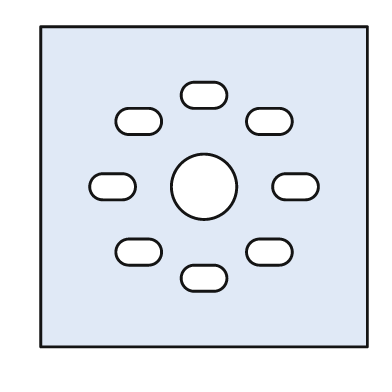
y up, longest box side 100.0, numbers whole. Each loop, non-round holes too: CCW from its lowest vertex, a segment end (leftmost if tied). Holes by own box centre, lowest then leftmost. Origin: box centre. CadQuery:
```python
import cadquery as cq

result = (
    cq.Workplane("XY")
    .moveTo(-50.0, -49.0)
    .lineTo(50.0, -49.0)
    .lineTo(50.0, 49.0)
    .lineTo(-50.0, 49.0)
    .close()
    .moveTo(-3.0, -32.0)
    .lineTo(3.0, -32.0)
    .threePointArc((7.0, -28.0), (3.0, -24.0))
    .lineTo(-3.0, -24.0)
    .threePointArc((-7.0, -28.0), (-3.0, -32.0))
    .close()
    .moveTo(-23.0, -24.0)
    .lineTo(-17.0, -24.0)
    .threePointArc((-13.0, -20.0), (-17.0, -16.0))
    .lineTo(-23.0, -16.0)
    .threePointArc((-27.0, -20.0), (-23.0, -24.0))
    .close()
    .moveTo(17.0, -24.0)
    .lineTo(23.0, -24.0)
    .threePointArc((27.0, -20.0), (23.0, -16.0))
    .lineTo(17.0, -16.0)
    .threePointArc((13.0, -20.0), (17.0, -24.0))
    .close()
    .moveTo(-31.0, -4.0)
    .lineTo(-25.0, -4.0)
    .threePointArc((-21.0, 0.0), (-25.0, 4.0))
    .lineTo(-31.0, 4.0)
    .threePointArc((-35.0, 0.0), (-31.0, -4.0))
    .close()
    .moveTo(0.0, 0.0)
    .circle(10.0)
    .moveTo(25.0, -4.0)
    .lineTo(31.0, -4.0)
    .threePointArc((35.0, 0.0), (31.0, 4.0))
    .lineTo(25.0, 4.0)
    .threePointArc((21.0, 0.0), (25.0, -4.0))
    .close()
    .moveTo(-23.0, 16.0)
    .lineTo(-17.0, 16.0)
    .threePointArc((-13.0, 20.0), (-17.0, 24.0))
    .lineTo(-23.0, 24.0)
    .threePointArc((-27.0, 20.0), (-23.0, 16.0))
    .close()
    .moveTo(17.0, 16.0)
    .lineTo(23.0, 16.0)
    .threePointArc((27.0, 20.0), (23.0, 24.0))
    .lineTo(17.0, 24.0)
    .threePointArc((13.0, 20.0), (17.0, 16.0))
    .close()
    .moveTo(-3.0, 24.0)
    .lineTo(3.0, 24.0)
    .threePointArc((7.0, 28.0), (3.0, 32.0))
    .lineTo(-3.0, 32.0)
    .threePointArc((-7.0, 28.0), (-3.0, 24.0))
    .close()
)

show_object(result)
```